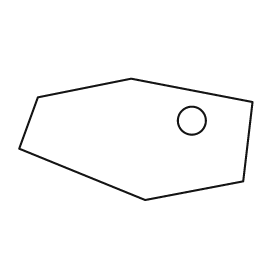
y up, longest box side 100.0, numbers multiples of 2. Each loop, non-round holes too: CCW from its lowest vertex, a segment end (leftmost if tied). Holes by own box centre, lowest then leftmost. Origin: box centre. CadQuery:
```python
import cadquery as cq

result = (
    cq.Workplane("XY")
    .moveTo(4.0, -26.0)
    .lineTo(46.0, -18.0)
    .lineTo(50.0, 16.0)
    .lineTo(-2.0, 26.0)
    .lineTo(-42.0, 18.0)
    .lineTo(-50.0, -4.0)
    .close()
    .moveTo(24.0, 8.0)
    .circle(6.0)
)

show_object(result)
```